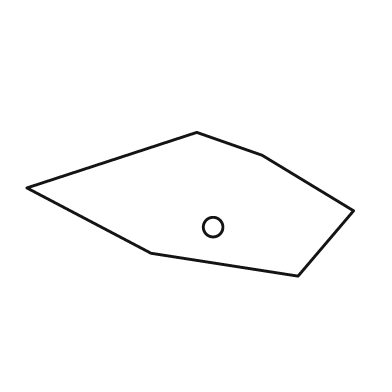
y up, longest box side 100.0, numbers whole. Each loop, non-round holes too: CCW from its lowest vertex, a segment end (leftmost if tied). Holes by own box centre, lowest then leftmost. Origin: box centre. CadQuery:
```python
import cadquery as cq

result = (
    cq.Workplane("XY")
    .moveTo(33.0, -22.0)
    .lineTo(50.0, -2.0)
    .lineTo(22.0, 15.0)
    .lineTo(2.0, 22.0)
    .lineTo(-50.0, 5.0)
    .lineTo(-12.0, -15.0)
    .close()
    .moveTo(7.0, -7.0)
    .circle(3.0)
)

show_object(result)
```